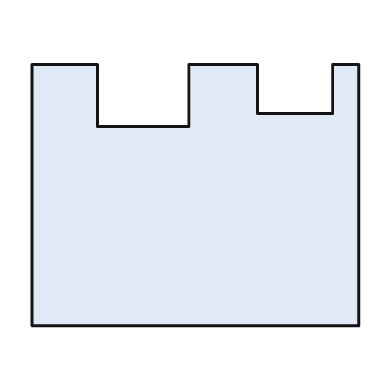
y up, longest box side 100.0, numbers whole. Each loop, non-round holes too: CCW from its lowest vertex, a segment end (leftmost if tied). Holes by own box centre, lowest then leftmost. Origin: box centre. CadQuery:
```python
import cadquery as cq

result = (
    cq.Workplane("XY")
    .moveTo(-50.0, -40.0)
    .lineTo(50.0, -40.0)
    .lineTo(50.0, 40.0)
    .lineTo(42.0, 40.0)
    .lineTo(42.0, 25.0)
    .lineTo(19.0, 25.0)
    .lineTo(19.0, 40.0)
    .lineTo(-2.0, 40.0)
    .lineTo(-2.0, 21.0)
    .lineTo(-30.0, 21.0)
    .lineTo(-30.0, 40.0)
    .lineTo(-50.0, 40.0)
    .close()
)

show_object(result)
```